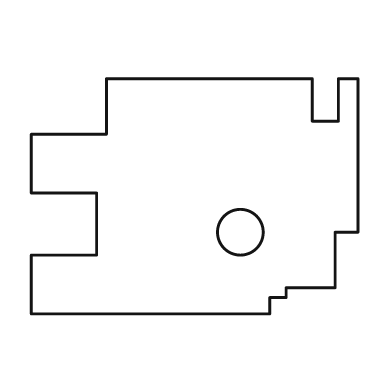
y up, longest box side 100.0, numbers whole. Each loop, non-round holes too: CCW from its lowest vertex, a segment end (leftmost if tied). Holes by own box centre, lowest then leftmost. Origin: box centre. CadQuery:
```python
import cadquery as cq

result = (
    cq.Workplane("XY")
    .moveTo(-50.0, -36.0)
    .lineTo(23.0, -36.0)
    .lineTo(23.0, -31.0)
    .lineTo(28.0, -31.0)
    .lineTo(28.0, -28.0)
    .lineTo(43.0, -28.0)
    .lineTo(43.0, -11.0)
    .lineTo(50.0, -11.0)
    .lineTo(50.0, 36.0)
    .lineTo(44.0, 36.0)
    .lineTo(44.0, 23.0)
    .lineTo(36.0, 23.0)
    .lineTo(36.0, 36.0)
    .lineTo(-27.0, 36.0)
    .lineTo(-27.0, 19.0)
    .lineTo(-50.0, 19.0)
    .lineTo(-50.0, 1.0)
    .lineTo(-30.0, 1.0)
    .lineTo(-30.0, -18.0)
    .lineTo(-50.0, -18.0)
    .close()
    .moveTo(14.0, -11.0)
    .circle(7.0)
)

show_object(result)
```